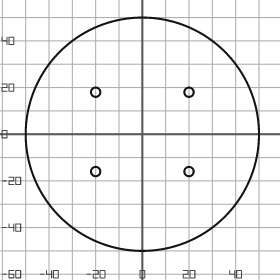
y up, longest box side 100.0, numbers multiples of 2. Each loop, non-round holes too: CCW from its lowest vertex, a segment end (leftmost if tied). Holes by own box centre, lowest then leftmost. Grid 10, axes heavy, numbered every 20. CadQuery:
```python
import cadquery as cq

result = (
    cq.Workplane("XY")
    .moveTo(0.0, 0.0)
    .circle(50.0)
    .moveTo(-20.0, -16.0)
    .circle(2.0)
    .moveTo(20.0, -16.0)
    .circle(2.0)
    .moveTo(-20.0, 18.0)
    .circle(2.0)
    .moveTo(20.0, 18.0)
    .circle(2.0)
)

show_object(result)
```